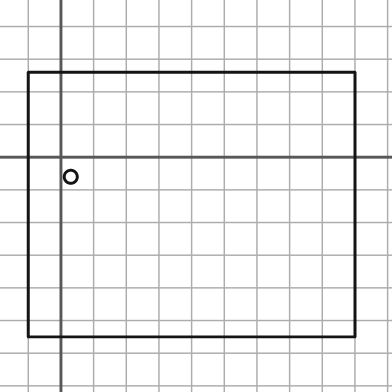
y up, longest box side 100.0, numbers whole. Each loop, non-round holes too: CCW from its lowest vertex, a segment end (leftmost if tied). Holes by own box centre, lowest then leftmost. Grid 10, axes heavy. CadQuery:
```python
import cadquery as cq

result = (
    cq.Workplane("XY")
    .moveTo(-10.0, -55.0)
    .lineTo(90.0, -55.0)
    .lineTo(90.0, 26.0)
    .lineTo(-10.0, 26.0)
    .close()
    .moveTo(3.0, -6.0)
    .circle(2.0)
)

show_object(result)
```